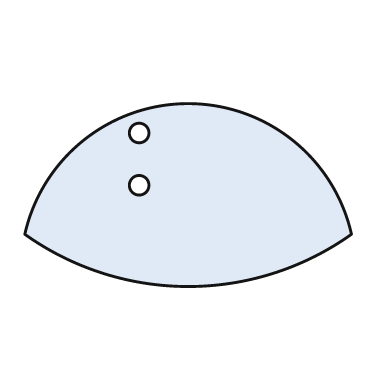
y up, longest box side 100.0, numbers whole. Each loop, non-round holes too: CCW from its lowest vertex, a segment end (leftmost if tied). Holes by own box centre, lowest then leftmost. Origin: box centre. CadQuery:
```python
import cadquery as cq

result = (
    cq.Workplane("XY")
    .moveTo(-50.0, -12.0)
    .threePointArc((0.0, -28.0), (50.0, -12.0))
    .threePointArc((0.0, 28.0), (-50.0, -12.0))
    .close()
    .moveTo(-15.0, 3.0)
    .circle(3.0)
    .moveTo(-15.0, 19.0)
    .circle(3.0)
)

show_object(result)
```